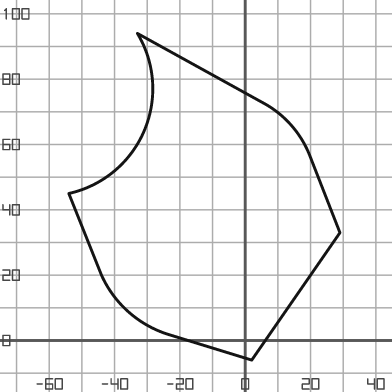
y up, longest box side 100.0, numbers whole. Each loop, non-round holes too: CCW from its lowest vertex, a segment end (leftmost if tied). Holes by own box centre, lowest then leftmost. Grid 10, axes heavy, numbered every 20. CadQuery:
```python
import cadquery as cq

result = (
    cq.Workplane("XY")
    .moveTo(2.0, -6.0)
    .lineTo(29.0, 33.0)
    .lineTo(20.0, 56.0)
    .threePointArc((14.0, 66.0), (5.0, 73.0))
    .lineTo(-33.0, 94.0)
    .threePointArc((-31.0, 64.0), (-54.0, 45.0))
    .lineTo(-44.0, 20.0)
    .threePointArc((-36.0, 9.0), (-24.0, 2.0))
    .close()
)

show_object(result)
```